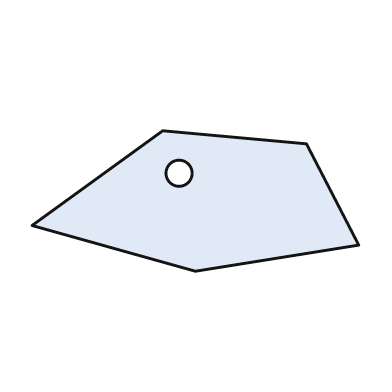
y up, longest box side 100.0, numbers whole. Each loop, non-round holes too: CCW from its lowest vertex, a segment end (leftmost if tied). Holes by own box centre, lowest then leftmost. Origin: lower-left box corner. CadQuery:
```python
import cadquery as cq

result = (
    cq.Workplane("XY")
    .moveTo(50.0, 0.0)
    .lineTo(100.0, 8.0)
    .lineTo(84.0, 39.0)
    .lineTo(40.0, 43.0)
    .lineTo(0.0, 14.0)
    .close()
    .moveTo(45.0, 30.0)
    .circle(4.0)
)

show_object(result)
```